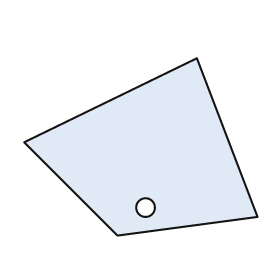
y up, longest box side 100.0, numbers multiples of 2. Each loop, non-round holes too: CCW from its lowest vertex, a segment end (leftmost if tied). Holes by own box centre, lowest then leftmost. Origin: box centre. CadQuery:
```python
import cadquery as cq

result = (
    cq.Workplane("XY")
    .moveTo(-10.0, -38.0)
    .lineTo(50.0, -30.0)
    .lineTo(24.0, 38.0)
    .lineTo(-50.0, 2.0)
    .close()
    .moveTo(2.0, -26.0)
    .circle(4.0)
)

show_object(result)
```